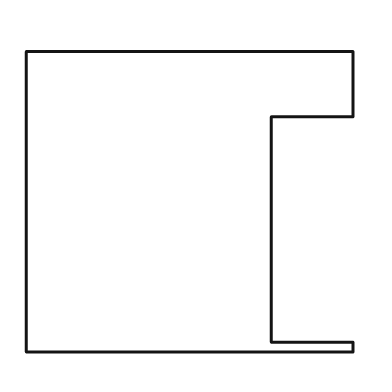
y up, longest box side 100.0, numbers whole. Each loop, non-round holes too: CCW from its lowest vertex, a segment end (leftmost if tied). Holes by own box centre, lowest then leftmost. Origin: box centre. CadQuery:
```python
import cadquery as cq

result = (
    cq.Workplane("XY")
    .moveTo(-50.0, -46.0)
    .lineTo(50.0, -46.0)
    .lineTo(50.0, -43.0)
    .lineTo(25.0, -43.0)
    .lineTo(25.0, 26.0)
    .lineTo(50.0, 26.0)
    .lineTo(50.0, 46.0)
    .lineTo(-50.0, 46.0)
    .close()
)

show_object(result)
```